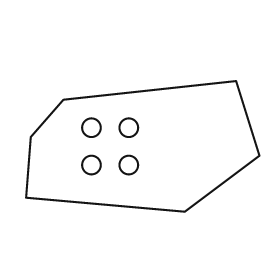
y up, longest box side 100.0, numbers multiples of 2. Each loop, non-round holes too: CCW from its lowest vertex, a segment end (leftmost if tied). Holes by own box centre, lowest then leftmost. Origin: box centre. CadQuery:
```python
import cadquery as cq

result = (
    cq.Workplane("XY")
    .moveTo(18.0, -28.0)
    .lineTo(50.0, -4.0)
    .lineTo(40.0, 28.0)
    .lineTo(-34.0, 20.0)
    .lineTo(-48.0, 4.0)
    .lineTo(-50.0, -22.0)
    .close()
    .moveTo(-22.0, -8.0)
    .circle(4.0)
    .moveTo(-6.0, -8.0)
    .circle(4.0)
    .moveTo(-22.0, 8.0)
    .circle(4.0)
    .moveTo(-6.0, 8.0)
    .circle(4.0)
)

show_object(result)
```